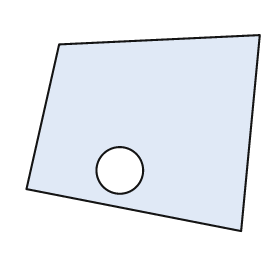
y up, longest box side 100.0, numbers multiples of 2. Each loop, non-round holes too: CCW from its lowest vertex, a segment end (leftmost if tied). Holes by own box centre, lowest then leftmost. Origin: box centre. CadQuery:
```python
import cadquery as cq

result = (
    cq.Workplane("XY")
    .moveTo(42.0, -42.0)
    .lineTo(50.0, 42.0)
    .lineTo(-36.0, 38.0)
    .lineTo(-50.0, -24.0)
    .close()
    .moveTo(-10.0, -16.0)
    .circle(10.0)
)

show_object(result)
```